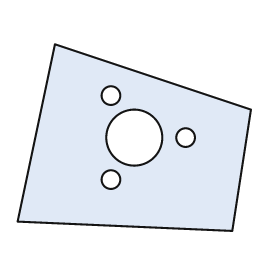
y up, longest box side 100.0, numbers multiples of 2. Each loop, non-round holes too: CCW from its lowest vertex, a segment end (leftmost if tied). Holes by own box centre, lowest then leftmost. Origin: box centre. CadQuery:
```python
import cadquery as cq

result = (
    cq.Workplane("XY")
    .moveTo(42.0, -40.0)
    .lineTo(50.0, 12.0)
    .lineTo(-34.0, 40.0)
    .lineTo(-50.0, -36.0)
    .close()
    .moveTo(-10.0, -18.0)
    .circle(4.0)
    .moveTo(0.0, 0.0)
    .circle(12.0)
    .moveTo(22.0, 0.0)
    .circle(4.0)
    .moveTo(-10.0, 18.0)
    .circle(4.0)
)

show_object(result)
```